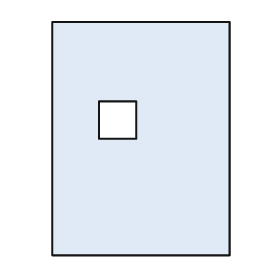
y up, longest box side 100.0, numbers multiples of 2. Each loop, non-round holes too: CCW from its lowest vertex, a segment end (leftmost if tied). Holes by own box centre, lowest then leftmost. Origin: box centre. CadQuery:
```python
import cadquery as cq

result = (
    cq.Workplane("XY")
    .moveTo(-38.0, -50.0)
    .lineTo(38.0, -50.0)
    .lineTo(38.0, 50.0)
    .lineTo(-38.0, 50.0)
    .close()
    .moveTo(-18.0, 0.0)
    .lineTo(-2.0, 0.0)
    .lineTo(-2.0, 16.0)
    .lineTo(-18.0, 16.0)
    .close()
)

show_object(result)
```